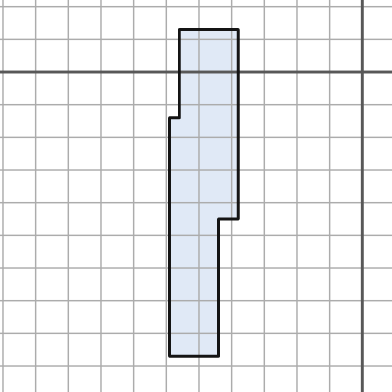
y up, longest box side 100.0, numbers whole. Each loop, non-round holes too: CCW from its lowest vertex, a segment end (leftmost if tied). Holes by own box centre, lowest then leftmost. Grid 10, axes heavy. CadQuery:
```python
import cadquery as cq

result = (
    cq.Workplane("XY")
    .moveTo(-59.0, -87.0)
    .lineTo(-44.0, -87.0)
    .lineTo(-44.0, -45.0)
    .lineTo(-38.0, -45.0)
    .lineTo(-38.0, 13.0)
    .lineTo(-56.0, 13.0)
    .lineTo(-56.0, -14.0)
    .lineTo(-59.0, -14.0)
    .close()
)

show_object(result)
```